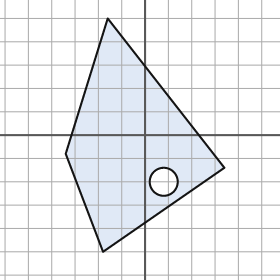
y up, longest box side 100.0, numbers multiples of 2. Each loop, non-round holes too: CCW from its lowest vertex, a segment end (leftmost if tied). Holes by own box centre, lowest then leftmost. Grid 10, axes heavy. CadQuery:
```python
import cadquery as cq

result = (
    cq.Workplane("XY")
    .moveTo(-18.0, -50.0)
    .lineTo(34.0, -14.0)
    .lineTo(-16.0, 50.0)
    .lineTo(-34.0, -8.0)
    .close()
    .moveTo(8.0, -20.0)
    .circle(6.0)
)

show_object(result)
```